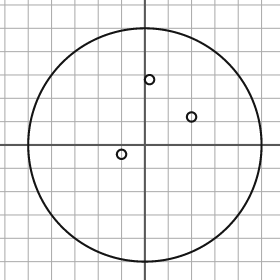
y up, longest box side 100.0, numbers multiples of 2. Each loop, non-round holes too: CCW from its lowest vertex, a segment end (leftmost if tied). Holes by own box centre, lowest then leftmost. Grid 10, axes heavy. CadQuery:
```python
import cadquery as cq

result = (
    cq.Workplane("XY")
    .moveTo(0.0, 0.0)
    .circle(50.0)
    .moveTo(-10.0, -4.0)
    .circle(2.0)
    .moveTo(20.0, 12.0)
    .circle(2.0)
    .moveTo(2.0, 28.0)
    .circle(2.0)
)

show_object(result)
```